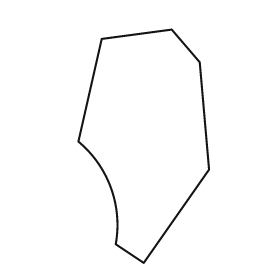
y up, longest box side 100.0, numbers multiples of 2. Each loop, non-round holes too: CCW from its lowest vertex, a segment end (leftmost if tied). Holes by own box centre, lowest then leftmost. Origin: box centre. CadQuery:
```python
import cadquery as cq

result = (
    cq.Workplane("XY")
    .moveTo(0.0, -50.0)
    .lineTo(28.0, -10.0)
    .lineTo(24.0, 36.0)
    .lineTo(12.0, 50.0)
    .lineTo(-18.0, 46.0)
    .lineTo(-28.0, 2.0)
    .threePointArc((-14.0, -18.0), (-12.0, -42.0))
    .close()
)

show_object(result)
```